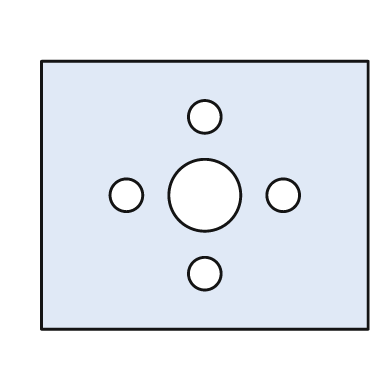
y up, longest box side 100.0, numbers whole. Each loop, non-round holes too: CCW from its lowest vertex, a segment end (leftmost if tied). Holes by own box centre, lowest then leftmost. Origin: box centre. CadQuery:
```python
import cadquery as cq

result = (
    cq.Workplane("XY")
    .moveTo(-50.0, -41.0)
    .lineTo(50.0, -41.0)
    .lineTo(50.0, 41.0)
    .lineTo(-50.0, 41.0)
    .close()
    .moveTo(0.0, -24.0)
    .circle(5.0)
    .moveTo(-24.0, 0.0)
    .circle(5.0)
    .moveTo(0.0, 0.0)
    .circle(11.0)
    .moveTo(24.0, 0.0)
    .circle(5.0)
    .moveTo(0.0, 24.0)
    .circle(5.0)
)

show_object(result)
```